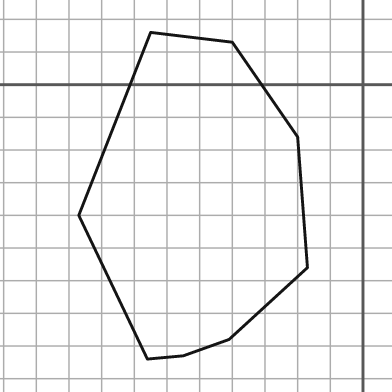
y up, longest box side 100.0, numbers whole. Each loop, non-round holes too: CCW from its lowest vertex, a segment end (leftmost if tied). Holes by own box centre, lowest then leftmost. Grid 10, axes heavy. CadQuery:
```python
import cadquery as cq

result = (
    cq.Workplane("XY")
    .moveTo(-66.0, -84.0)
    .lineTo(-55.0, -83.0)
    .lineTo(-41.0, -78.0)
    .lineTo(-17.0, -56.0)
    .lineTo(-20.0, -16.0)
    .lineTo(-40.0, 13.0)
    .lineTo(-65.0, 16.0)
    .lineTo(-87.0, -40.0)
    .close()
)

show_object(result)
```